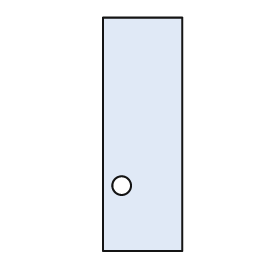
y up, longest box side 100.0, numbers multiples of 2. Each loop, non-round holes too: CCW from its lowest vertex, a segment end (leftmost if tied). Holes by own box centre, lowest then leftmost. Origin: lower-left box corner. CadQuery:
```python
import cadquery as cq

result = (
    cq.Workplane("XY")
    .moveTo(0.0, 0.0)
    .lineTo(34.0, 0.0)
    .lineTo(34.0, 100.0)
    .lineTo(0.0, 100.0)
    .close()
    .moveTo(8.0, 28.0)
    .circle(4.0)
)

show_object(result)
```